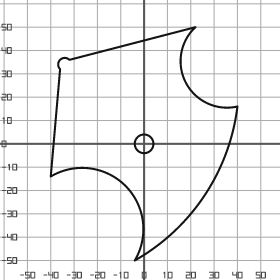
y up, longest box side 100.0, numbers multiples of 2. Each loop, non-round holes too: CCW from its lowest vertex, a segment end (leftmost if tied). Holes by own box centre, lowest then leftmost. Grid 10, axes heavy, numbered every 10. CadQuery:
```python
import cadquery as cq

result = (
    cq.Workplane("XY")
    .moveTo(-4.0, -50.0)
    .threePointArc((26.0, -22.0), (40.0, 16.0))
    .threePointArc((18.0, 26.0), (22.0, 50.0))
    .lineTo(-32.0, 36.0)
    .threePointArc((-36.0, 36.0), (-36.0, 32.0))
    .lineTo(-40.0, -14.0)
    .threePointArc((-8.0, -18.0), (-4.0, -50.0))
    .close()
    .moveTo(0.0, 0.0)
    .circle(4.0)
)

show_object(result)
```